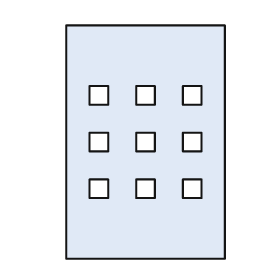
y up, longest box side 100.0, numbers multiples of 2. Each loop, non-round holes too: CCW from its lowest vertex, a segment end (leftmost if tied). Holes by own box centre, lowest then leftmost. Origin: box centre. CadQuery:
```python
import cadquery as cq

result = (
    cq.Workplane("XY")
    .moveTo(-34.0, -50.0)
    .lineTo(34.0, -50.0)
    .lineTo(34.0, 50.0)
    .lineTo(-34.0, 50.0)
    .close()
    .moveTo(-24.0, -24.0)
    .lineTo(-16.0, -24.0)
    .lineTo(-16.0, -16.0)
    .lineTo(-24.0, -16.0)
    .close()
    .moveTo(-4.0, -24.0)
    .lineTo(4.0, -24.0)
    .lineTo(4.0, -16.0)
    .lineTo(-4.0, -16.0)
    .close()
    .moveTo(16.0, -24.0)
    .lineTo(24.0, -24.0)
    .lineTo(24.0, -16.0)
    .lineTo(16.0, -16.0)
    .close()
    .moveTo(-24.0, -4.0)
    .lineTo(-16.0, -4.0)
    .lineTo(-16.0, 4.0)
    .lineTo(-24.0, 4.0)
    .close()
    .moveTo(-4.0, -4.0)
    .lineTo(4.0, -4.0)
    .lineTo(4.0, 4.0)
    .lineTo(-4.0, 4.0)
    .close()
    .moveTo(16.0, -4.0)
    .lineTo(24.0, -4.0)
    .lineTo(24.0, 4.0)
    .lineTo(16.0, 4.0)
    .close()
    .moveTo(-24.0, 16.0)
    .lineTo(-16.0, 16.0)
    .lineTo(-16.0, 24.0)
    .lineTo(-24.0, 24.0)
    .close()
    .moveTo(-4.0, 16.0)
    .lineTo(4.0, 16.0)
    .lineTo(4.0, 24.0)
    .lineTo(-4.0, 24.0)
    .close()
    .moveTo(16.0, 16.0)
    .lineTo(24.0, 16.0)
    .lineTo(24.0, 24.0)
    .lineTo(16.0, 24.0)
    .close()
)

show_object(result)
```